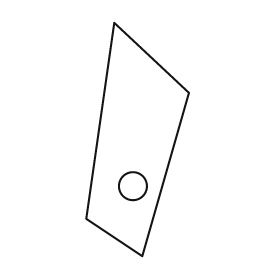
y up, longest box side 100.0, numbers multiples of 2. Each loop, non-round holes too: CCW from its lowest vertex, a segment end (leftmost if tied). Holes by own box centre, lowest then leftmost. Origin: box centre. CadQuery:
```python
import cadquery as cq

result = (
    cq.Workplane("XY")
    .moveTo(2.0, -50.0)
    .lineTo(22.0, 20.0)
    .lineTo(-10.0, 50.0)
    .lineTo(-22.0, -34.0)
    .close()
    .moveTo(-2.0, -20.0)
    .circle(6.0)
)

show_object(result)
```